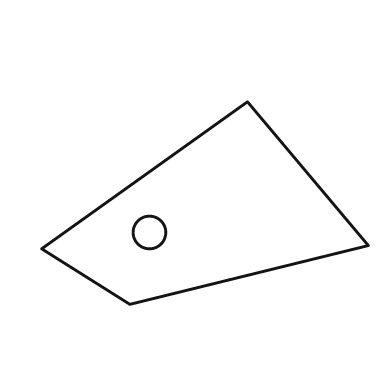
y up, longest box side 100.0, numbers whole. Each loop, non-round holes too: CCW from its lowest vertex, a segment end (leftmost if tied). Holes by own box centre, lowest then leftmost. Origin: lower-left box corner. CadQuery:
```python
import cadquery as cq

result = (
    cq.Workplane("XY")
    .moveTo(27.0, 0.0)
    .lineTo(100.0, 18.0)
    .lineTo(63.0, 62.0)
    .lineTo(0.0, 17.0)
    .close()
    .moveTo(33.0, 22.0)
    .circle(5.0)
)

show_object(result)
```